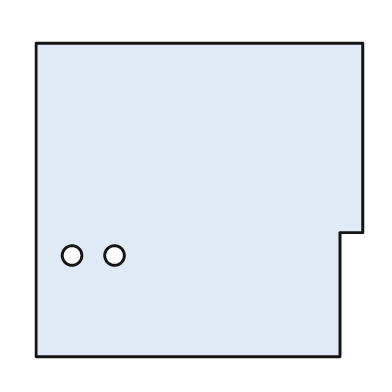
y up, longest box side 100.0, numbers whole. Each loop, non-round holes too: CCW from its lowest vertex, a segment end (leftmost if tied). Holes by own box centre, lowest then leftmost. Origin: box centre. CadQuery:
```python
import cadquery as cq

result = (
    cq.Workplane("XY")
    .moveTo(-50.0, -48.0)
    .lineTo(43.0, -48.0)
    .lineTo(43.0, -10.0)
    .lineTo(50.0, -10.0)
    .lineTo(50.0, 48.0)
    .lineTo(-50.0, 48.0)
    .close()
    .moveTo(-39.0, -17.0)
    .circle(3.0)
    .moveTo(-26.0, -17.0)
    .circle(3.0)
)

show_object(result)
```